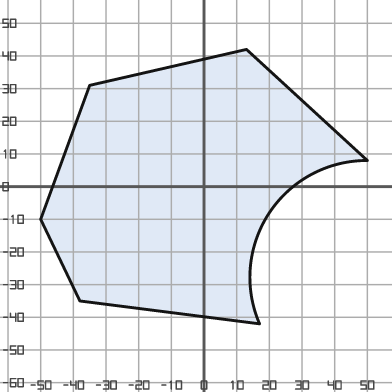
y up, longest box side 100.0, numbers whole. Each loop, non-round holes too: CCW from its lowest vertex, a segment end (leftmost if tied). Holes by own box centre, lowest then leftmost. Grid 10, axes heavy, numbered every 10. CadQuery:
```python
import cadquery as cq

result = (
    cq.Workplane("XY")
    .moveTo(17.0, -42.0)
    .threePointArc((20.0, -8.0), (50.0, 8.0))
    .lineTo(13.0, 42.0)
    .lineTo(-35.0, 31.0)
    .lineTo(-50.0, -10.0)
    .lineTo(-38.0, -35.0)
    .close()
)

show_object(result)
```